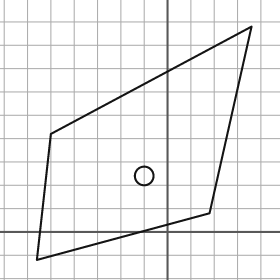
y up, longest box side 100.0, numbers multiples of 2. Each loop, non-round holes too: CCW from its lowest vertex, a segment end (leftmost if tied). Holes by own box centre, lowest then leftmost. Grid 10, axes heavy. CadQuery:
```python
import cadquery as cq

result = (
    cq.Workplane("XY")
    .moveTo(-56.0, -12.0)
    .lineTo(18.0, 8.0)
    .lineTo(36.0, 88.0)
    .lineTo(-50.0, 42.0)
    .close()
    .moveTo(-10.0, 24.0)
    .circle(4.0)
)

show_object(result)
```